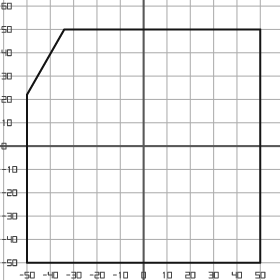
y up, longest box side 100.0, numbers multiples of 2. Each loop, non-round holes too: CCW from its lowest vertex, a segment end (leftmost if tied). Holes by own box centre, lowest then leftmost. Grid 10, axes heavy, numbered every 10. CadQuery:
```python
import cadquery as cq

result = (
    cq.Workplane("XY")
    .moveTo(-50.0, -50.0)
    .lineTo(50.0, -50.0)
    .lineTo(50.0, 50.0)
    .lineTo(-34.0, 50.0)
    .lineTo(-50.0, 22.0)
    .close()
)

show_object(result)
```